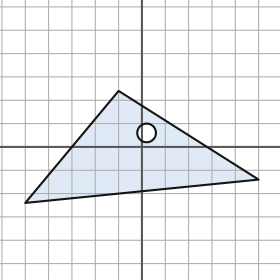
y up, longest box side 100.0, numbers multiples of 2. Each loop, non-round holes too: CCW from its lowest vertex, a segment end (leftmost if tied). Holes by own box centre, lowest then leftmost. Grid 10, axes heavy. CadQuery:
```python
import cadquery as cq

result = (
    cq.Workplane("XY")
    .moveTo(-50.0, -24.0)
    .lineTo(50.0, -14.0)
    .lineTo(-10.0, 24.0)
    .close()
    .moveTo(2.0, 6.0)
    .circle(4.0)
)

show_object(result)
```